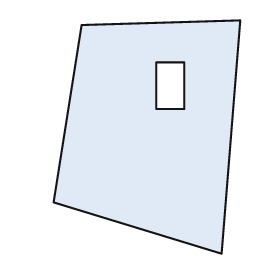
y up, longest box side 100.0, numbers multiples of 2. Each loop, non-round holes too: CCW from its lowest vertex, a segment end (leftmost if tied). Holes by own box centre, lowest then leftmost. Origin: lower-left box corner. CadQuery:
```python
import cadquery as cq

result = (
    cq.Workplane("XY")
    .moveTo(72.0, 0.0)
    .lineTo(80.0, 100.0)
    .lineTo(12.0, 98.0)
    .lineTo(0.0, 22.0)
    .close()
    .moveTo(44.0, 62.0)
    .lineTo(56.0, 62.0)
    .lineTo(56.0, 82.0)
    .lineTo(44.0, 82.0)
    .close()
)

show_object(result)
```